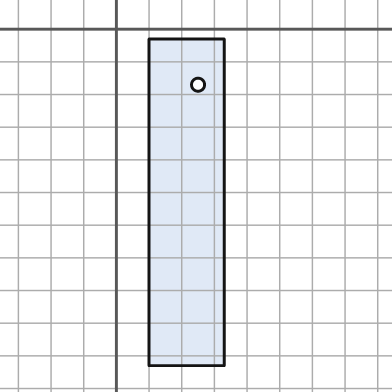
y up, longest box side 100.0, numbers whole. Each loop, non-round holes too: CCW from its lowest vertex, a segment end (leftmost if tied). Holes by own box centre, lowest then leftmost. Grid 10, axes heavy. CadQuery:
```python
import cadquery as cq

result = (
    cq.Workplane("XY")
    .moveTo(10.0, -103.0)
    .lineTo(33.0, -103.0)
    .lineTo(33.0, -3.0)
    .lineTo(10.0, -3.0)
    .close()
    .moveTo(25.0, -17.0)
    .circle(2.0)
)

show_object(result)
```